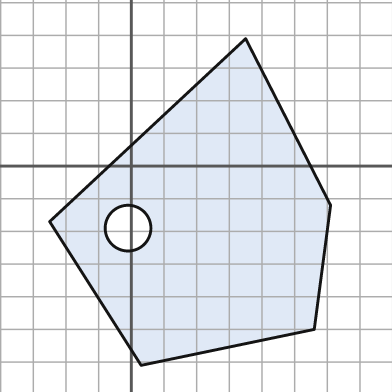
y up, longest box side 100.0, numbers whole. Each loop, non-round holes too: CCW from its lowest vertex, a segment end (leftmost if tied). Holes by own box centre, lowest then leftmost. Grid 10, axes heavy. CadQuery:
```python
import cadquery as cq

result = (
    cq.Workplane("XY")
    .moveTo(3.0, -61.0)
    .lineTo(56.0, -50.0)
    .lineTo(61.0, -12.0)
    .lineTo(35.0, 39.0)
    .lineTo(-25.0, -17.0)
    .close()
    .moveTo(-1.0, -19.0)
    .circle(7.0)
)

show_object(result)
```